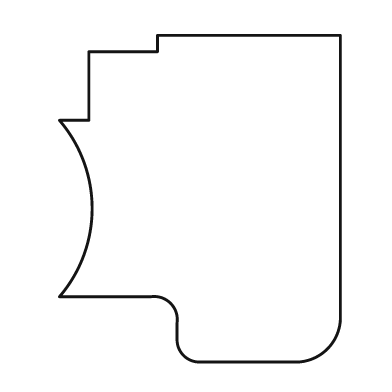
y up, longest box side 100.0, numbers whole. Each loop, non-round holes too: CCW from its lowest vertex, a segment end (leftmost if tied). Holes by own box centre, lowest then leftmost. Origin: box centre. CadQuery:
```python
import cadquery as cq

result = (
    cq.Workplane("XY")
    .moveTo(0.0, -50.0)
    .lineTo(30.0, -50.0)
    .threePointArc((39.0, -46.0), (43.0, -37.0))
    .lineTo(43.0, 50.0)
    .lineTo(-13.0, 50.0)
    .lineTo(-13.0, 45.0)
    .lineTo(-34.0, 45.0)
    .lineTo(-34.0, 24.0)
    .lineTo(-43.0, 24.0)
    .threePointArc((-33.0, -3.0), (-43.0, -30.0))
    .lineTo(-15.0, -30.0)
    .threePointArc((-9.0, -32.0), (-7.0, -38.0))
    .lineTo(-7.0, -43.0)
    .threePointArc((-5.0, -48.0), (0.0, -50.0))
    .close()
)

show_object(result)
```